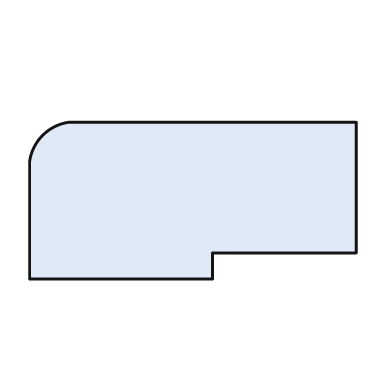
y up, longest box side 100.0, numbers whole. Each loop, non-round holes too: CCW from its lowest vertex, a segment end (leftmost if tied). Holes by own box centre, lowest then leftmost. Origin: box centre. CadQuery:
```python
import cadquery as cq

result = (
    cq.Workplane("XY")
    .moveTo(-50.0, -24.0)
    .lineTo(6.0, -24.0)
    .lineTo(6.0, -16.0)
    .lineTo(50.0, -16.0)
    .lineTo(50.0, 24.0)
    .lineTo(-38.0, 24.0)
    .threePointArc((-46.0, 20.0), (-50.0, 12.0))
    .close()
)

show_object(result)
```